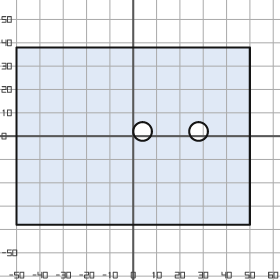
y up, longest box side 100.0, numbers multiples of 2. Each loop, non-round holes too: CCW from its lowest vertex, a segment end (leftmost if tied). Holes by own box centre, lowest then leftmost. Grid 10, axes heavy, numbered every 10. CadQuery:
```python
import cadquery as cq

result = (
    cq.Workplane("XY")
    .moveTo(-50.0, -38.0)
    .lineTo(50.0, -38.0)
    .lineTo(50.0, 38.0)
    .lineTo(-50.0, 38.0)
    .close()
    .moveTo(4.0, 2.0)
    .circle(4.0)
    .moveTo(28.0, 2.0)
    .circle(4.0)
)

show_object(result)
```